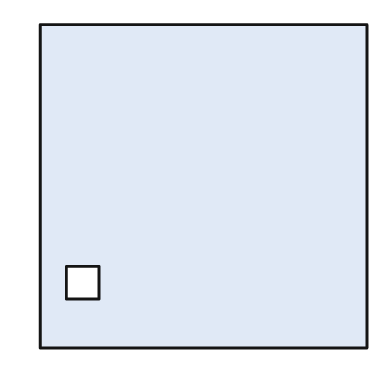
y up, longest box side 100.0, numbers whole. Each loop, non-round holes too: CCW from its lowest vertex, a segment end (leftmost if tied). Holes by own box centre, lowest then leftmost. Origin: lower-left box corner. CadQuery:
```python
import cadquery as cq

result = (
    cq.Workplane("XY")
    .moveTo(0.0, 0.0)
    .lineTo(100.0, 0.0)
    .lineTo(100.0, 99.0)
    .lineTo(0.0, 99.0)
    .close()
    .moveTo(8.0, 15.0)
    .lineTo(18.0, 15.0)
    .lineTo(18.0, 25.0)
    .lineTo(8.0, 25.0)
    .close()
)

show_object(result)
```